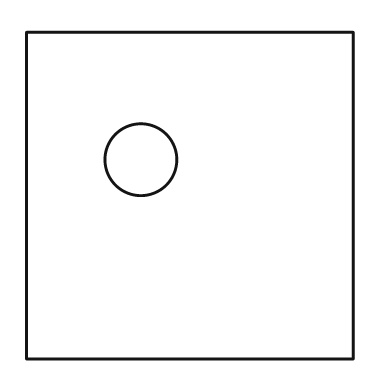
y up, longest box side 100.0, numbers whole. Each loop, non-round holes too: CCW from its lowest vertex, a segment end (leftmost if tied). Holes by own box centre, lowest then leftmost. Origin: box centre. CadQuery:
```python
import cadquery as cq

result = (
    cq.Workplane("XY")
    .moveTo(-50.0, -50.0)
    .lineTo(50.0, -50.0)
    .lineTo(50.0, 50.0)
    .lineTo(-50.0, 50.0)
    .close()
    .moveTo(-15.0, 11.0)
    .circle(11.0)
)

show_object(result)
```